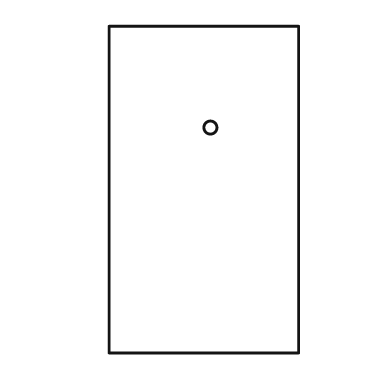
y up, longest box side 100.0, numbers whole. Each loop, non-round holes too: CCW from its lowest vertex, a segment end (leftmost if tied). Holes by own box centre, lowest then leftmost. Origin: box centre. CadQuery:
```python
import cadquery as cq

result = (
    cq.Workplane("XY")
    .moveTo(-29.0, -50.0)
    .lineTo(29.0, -50.0)
    .lineTo(29.0, 50.0)
    .lineTo(-29.0, 50.0)
    .close()
    .moveTo(2.0, 19.0)
    .circle(2.0)
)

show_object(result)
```